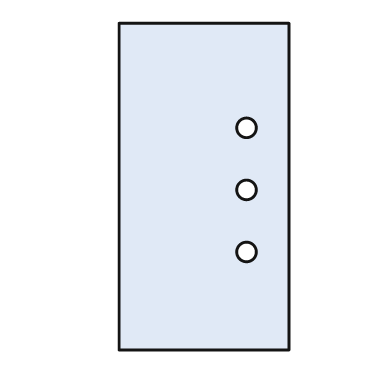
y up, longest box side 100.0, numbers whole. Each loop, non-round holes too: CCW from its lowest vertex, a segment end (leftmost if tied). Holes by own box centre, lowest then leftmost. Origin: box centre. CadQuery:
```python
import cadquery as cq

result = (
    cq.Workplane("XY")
    .moveTo(-26.0, -50.0)
    .lineTo(26.0, -50.0)
    .lineTo(26.0, 50.0)
    .lineTo(-26.0, 50.0)
    .close()
    .moveTo(13.0, -20.0)
    .circle(3.0)
    .moveTo(13.0, -1.0)
    .circle(3.0)
    .moveTo(13.0, 18.0)
    .circle(3.0)
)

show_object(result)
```